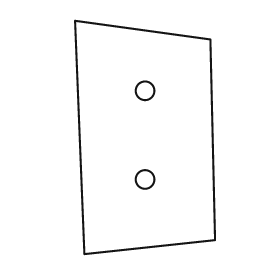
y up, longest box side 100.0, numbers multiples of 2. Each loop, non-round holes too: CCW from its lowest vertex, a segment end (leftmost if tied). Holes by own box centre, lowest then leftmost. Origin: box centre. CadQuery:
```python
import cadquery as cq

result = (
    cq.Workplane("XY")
    .moveTo(-26.0, -50.0)
    .lineTo(30.0, -44.0)
    .lineTo(28.0, 42.0)
    .lineTo(-30.0, 50.0)
    .close()
    .moveTo(0.0, -18.0)
    .circle(4.0)
    .moveTo(0.0, 20.0)
    .circle(4.0)
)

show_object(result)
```